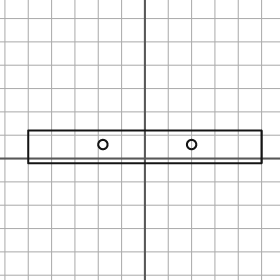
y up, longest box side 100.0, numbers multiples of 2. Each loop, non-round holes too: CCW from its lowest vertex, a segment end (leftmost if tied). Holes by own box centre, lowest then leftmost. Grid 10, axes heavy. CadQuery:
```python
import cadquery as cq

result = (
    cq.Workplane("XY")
    .moveTo(-50.0, -2.0)
    .lineTo(50.0, -2.0)
    .lineTo(50.0, 12.0)
    .lineTo(-50.0, 12.0)
    .close()
    .moveTo(-18.0, 6.0)
    .circle(2.0)
    .moveTo(20.0, 6.0)
    .circle(2.0)
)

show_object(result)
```